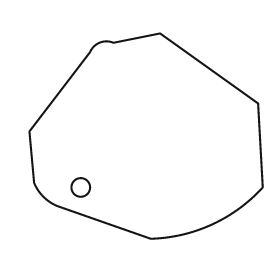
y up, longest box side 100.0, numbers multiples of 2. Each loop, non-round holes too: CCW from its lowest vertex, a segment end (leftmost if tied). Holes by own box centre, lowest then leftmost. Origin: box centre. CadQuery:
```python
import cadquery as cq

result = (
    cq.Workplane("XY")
    .moveTo(2.0, -44.0)
    .threePointArc((28.0, -38.0), (50.0, -22.0))
    .lineTo(48.0, 14.0)
    .lineTo(6.0, 44.0)
    .lineTo(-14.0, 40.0)
    .threePointArc((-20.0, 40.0), (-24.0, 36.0))
    .lineTo(-50.0, 2.0)
    .lineTo(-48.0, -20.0)
    .threePointArc((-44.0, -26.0), (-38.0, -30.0))
    .close()
    .moveTo(-28.0, -22.0)
    .circle(4.0)
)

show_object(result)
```